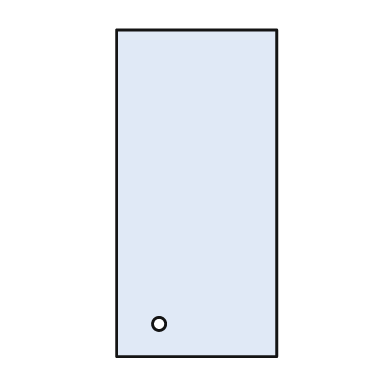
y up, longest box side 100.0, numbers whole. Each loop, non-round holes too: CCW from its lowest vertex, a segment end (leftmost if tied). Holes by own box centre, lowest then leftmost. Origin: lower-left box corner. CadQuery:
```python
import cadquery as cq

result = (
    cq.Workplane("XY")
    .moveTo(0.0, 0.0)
    .lineTo(49.0, 0.0)
    .lineTo(49.0, 100.0)
    .lineTo(0.0, 100.0)
    .close()
    .moveTo(13.0, 10.0)
    .circle(2.0)
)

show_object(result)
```